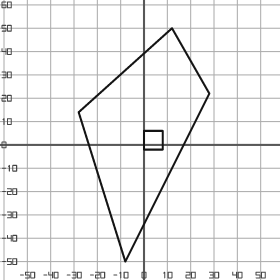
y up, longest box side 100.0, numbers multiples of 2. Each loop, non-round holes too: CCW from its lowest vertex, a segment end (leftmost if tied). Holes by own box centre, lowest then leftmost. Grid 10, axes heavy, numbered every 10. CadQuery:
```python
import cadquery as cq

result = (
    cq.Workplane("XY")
    .moveTo(-8.0, -50.0)
    .lineTo(28.0, 22.0)
    .lineTo(12.0, 50.0)
    .lineTo(-28.0, 14.0)
    .close()
    .moveTo(0.0, -2.0)
    .lineTo(8.0, -2.0)
    .lineTo(8.0, 6.0)
    .lineTo(0.0, 6.0)
    .close()
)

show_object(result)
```